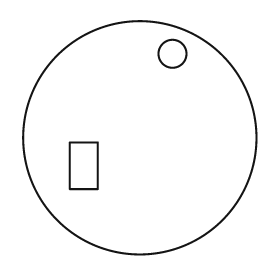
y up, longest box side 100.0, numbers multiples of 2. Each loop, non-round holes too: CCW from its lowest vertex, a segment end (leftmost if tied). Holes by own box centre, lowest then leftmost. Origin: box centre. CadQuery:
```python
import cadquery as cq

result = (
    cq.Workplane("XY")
    .moveTo(0.0, 0.0)
    .circle(50.0)
    .moveTo(-30.0, -22.0)
    .lineTo(-18.0, -22.0)
    .lineTo(-18.0, -2.0)
    .lineTo(-30.0, -2.0)
    .close()
    .moveTo(14.0, 36.0)
    .circle(6.0)
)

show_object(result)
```